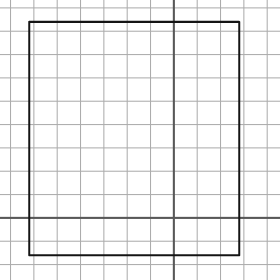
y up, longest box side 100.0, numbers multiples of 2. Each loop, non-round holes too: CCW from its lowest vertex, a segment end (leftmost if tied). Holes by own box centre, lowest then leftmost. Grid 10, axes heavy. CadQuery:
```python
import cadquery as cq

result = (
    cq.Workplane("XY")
    .moveTo(-62.0, -16.0)
    .lineTo(28.0, -16.0)
    .lineTo(28.0, 84.0)
    .lineTo(-62.0, 84.0)
    .close()
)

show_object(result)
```